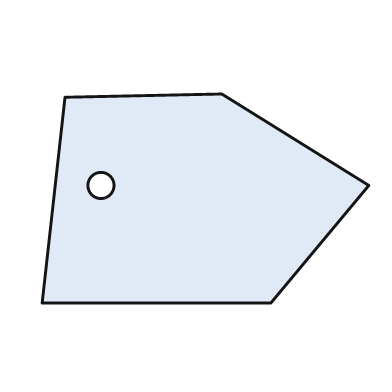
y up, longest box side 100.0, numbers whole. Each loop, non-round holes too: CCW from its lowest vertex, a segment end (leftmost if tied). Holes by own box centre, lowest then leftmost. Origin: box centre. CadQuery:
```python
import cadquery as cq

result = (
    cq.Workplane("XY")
    .moveTo(-50.0, -32.0)
    .lineTo(20.0, -32.0)
    .lineTo(50.0, 4.0)
    .lineTo(5.0, 32.0)
    .lineTo(-43.0, 31.0)
    .close()
    .moveTo(-32.0, 4.0)
    .circle(4.0)
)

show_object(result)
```